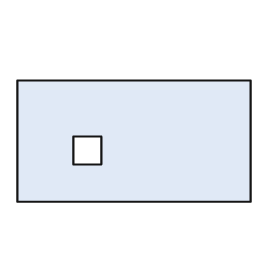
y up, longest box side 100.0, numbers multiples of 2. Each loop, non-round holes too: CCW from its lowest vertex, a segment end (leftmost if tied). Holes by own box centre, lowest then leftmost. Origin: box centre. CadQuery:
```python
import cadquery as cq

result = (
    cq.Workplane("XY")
    .moveTo(-50.0, -26.0)
    .lineTo(50.0, -26.0)
    .lineTo(50.0, 26.0)
    .lineTo(-50.0, 26.0)
    .close()
    .moveTo(-26.0, -10.0)
    .lineTo(-14.0, -10.0)
    .lineTo(-14.0, 2.0)
    .lineTo(-26.0, 2.0)
    .close()
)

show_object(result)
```